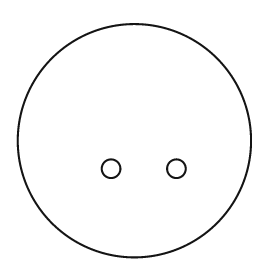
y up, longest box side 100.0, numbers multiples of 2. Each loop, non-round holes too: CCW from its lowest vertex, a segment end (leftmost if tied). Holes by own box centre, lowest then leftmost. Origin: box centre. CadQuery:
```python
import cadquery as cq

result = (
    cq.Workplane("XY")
    .moveTo(0.0, 0.0)
    .circle(50.0)
    .moveTo(-10.0, -12.0)
    .circle(4.0)
    .moveTo(18.0, -12.0)
    .circle(4.0)
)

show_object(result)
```